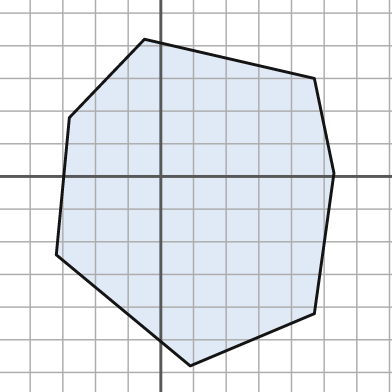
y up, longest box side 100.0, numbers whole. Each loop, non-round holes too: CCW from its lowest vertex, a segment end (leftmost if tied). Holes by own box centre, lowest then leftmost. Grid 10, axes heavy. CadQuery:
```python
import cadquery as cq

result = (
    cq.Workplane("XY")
    .moveTo(9.0, -58.0)
    .lineTo(47.0, -42.0)
    .lineTo(53.0, 1.0)
    .lineTo(47.0, 30.0)
    .lineTo(-5.0, 42.0)
    .lineTo(-28.0, 18.0)
    .lineTo(-32.0, -24.0)
    .close()
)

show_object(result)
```